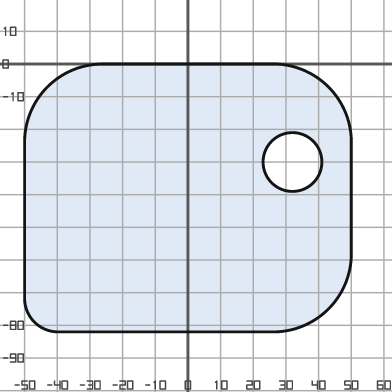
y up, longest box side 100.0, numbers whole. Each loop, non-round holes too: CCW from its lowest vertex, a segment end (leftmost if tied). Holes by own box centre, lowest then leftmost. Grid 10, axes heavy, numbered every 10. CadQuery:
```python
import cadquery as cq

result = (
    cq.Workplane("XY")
    .moveTo(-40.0, -82.0)
    .lineTo(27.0, -82.0)
    .threePointArc((43.0, -75.0), (50.0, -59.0))
    .lineTo(50.0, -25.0)
    .threePointArc((43.0, -7.0), (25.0, 0.0))
    .lineTo(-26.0, 0.0)
    .threePointArc((-43.0, -7.0), (-50.0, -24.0))
    .lineTo(-50.0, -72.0)
    .threePointArc((-47.0, -79.0), (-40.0, -82.0))
    .close()
    .moveTo(32.0, -30.0)
    .circle(9.0)
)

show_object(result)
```